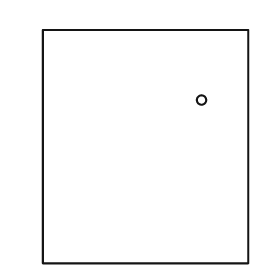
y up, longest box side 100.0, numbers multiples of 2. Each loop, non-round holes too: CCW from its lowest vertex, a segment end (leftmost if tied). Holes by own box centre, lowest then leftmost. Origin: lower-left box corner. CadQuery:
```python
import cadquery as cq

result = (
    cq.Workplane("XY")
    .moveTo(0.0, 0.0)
    .lineTo(88.0, 0.0)
    .lineTo(88.0, 100.0)
    .lineTo(0.0, 100.0)
    .close()
    .moveTo(68.0, 70.0)
    .circle(2.0)
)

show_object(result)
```